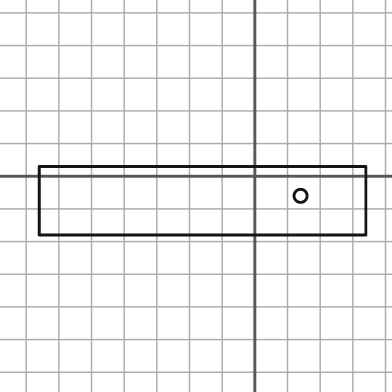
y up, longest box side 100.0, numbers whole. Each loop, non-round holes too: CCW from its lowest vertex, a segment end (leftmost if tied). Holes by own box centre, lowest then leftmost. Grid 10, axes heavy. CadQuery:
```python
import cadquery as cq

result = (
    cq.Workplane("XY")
    .moveTo(-66.0, -18.0)
    .lineTo(34.0, -18.0)
    .lineTo(34.0, 3.0)
    .lineTo(-66.0, 3.0)
    .close()
    .moveTo(14.0, -6.0)
    .circle(2.0)
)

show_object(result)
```